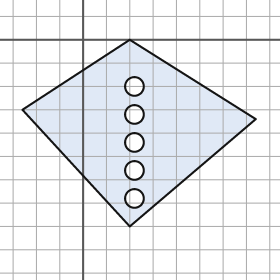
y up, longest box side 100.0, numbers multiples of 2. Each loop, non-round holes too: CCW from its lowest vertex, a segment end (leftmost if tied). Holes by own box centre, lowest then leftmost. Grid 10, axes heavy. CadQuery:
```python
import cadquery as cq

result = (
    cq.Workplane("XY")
    .moveTo(20.0, -80.0)
    .lineTo(74.0, -34.0)
    .lineTo(20.0, 0.0)
    .lineTo(-26.0, -30.0)
    .close()
    .moveTo(22.0, -68.0)
    .circle(4.0)
    .moveTo(22.0, -56.0)
    .circle(4.0)
    .moveTo(22.0, -44.0)
    .circle(4.0)
    .moveTo(22.0, -32.0)
    .circle(4.0)
    .moveTo(22.0, -20.0)
    .circle(4.0)
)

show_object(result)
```